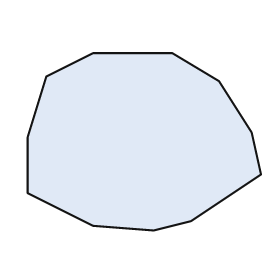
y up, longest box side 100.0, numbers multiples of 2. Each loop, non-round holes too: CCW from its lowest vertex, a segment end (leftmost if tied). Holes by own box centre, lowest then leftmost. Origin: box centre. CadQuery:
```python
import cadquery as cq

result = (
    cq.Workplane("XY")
    .moveTo(4.0, -38.0)
    .lineTo(20.0, -34.0)
    .lineTo(50.0, -14.0)
    .lineTo(46.0, 4.0)
    .lineTo(32.0, 26.0)
    .lineTo(12.0, 38.0)
    .lineTo(-22.0, 38.0)
    .lineTo(-42.0, 28.0)
    .lineTo(-50.0, 2.0)
    .lineTo(-50.0, -22.0)
    .lineTo(-22.0, -36.0)
    .close()
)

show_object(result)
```